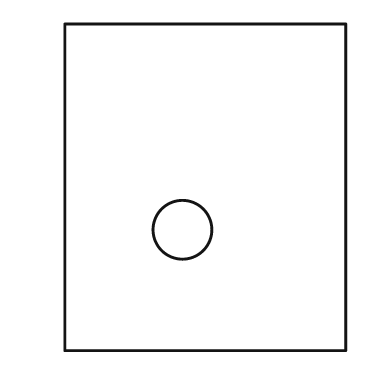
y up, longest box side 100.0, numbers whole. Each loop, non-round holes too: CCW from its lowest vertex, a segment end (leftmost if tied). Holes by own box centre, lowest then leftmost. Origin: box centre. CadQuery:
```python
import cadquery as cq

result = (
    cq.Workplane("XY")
    .moveTo(-43.0, -50.0)
    .lineTo(43.0, -50.0)
    .lineTo(43.0, 50.0)
    .lineTo(-43.0, 50.0)
    .close()
    .moveTo(-7.0, -13.0)
    .circle(9.0)
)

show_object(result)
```